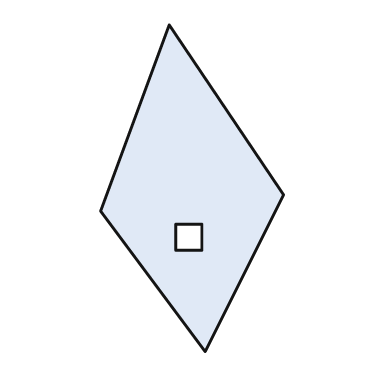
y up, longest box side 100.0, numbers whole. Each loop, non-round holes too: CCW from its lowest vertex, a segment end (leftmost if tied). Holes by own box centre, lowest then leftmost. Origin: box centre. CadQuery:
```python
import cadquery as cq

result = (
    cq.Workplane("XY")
    .moveTo(4.0, -50.0)
    .lineTo(28.0, -2.0)
    .lineTo(-7.0, 50.0)
    .lineTo(-28.0, -7.0)
    .close()
    .moveTo(-5.0, -19.0)
    .lineTo(3.0, -19.0)
    .lineTo(3.0, -11.0)
    .lineTo(-5.0, -11.0)
    .close()
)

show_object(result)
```